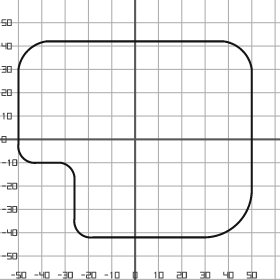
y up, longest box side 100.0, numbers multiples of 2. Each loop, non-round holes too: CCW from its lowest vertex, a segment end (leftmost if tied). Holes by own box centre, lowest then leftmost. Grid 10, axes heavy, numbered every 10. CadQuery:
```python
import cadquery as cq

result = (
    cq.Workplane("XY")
    .moveTo(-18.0, -42.0)
    .lineTo(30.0, -42.0)
    .threePointArc((44.0, -36.0), (50.0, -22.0))
    .lineTo(50.0, 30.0)
    .threePointArc((46.0, 38.0), (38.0, 42.0))
    .lineTo(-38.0, 42.0)
    .threePointArc((-46.0, 38.0), (-50.0, 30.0))
    .lineTo(-50.0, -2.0)
    .threePointArc((-48.0, -8.0), (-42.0, -10.0))
    .lineTo(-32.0, -10.0)
    .threePointArc((-28.0, -12.0), (-26.0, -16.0))
    .lineTo(-26.0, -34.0)
    .threePointArc((-24.0, -40.0), (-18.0, -42.0))
    .close()
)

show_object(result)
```